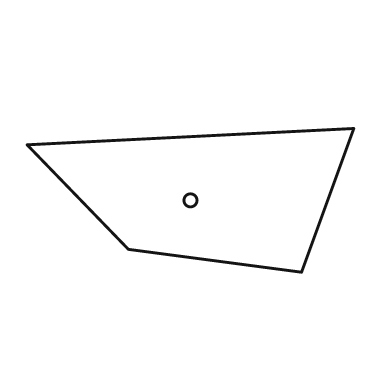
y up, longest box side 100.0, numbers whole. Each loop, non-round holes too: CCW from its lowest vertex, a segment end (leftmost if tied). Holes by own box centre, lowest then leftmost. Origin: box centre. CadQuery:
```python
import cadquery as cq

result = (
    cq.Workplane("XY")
    .moveTo(34.0, -22.0)
    .lineTo(50.0, 22.0)
    .lineTo(-50.0, 17.0)
    .lineTo(-19.0, -15.0)
    .close()
    .moveTo(0.0, 0.0)
    .circle(2.0)
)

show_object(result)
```